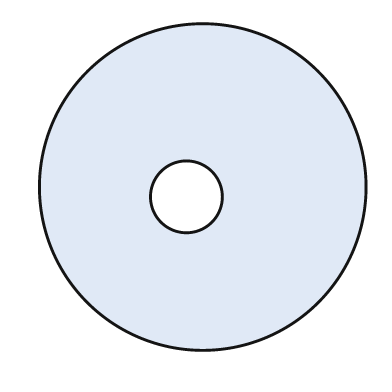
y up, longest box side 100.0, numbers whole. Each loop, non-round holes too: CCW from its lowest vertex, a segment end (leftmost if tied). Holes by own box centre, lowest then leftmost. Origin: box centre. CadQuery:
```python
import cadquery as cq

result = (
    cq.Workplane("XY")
    .moveTo(0.0, 0.0)
    .circle(50.0)
    .moveTo(-5.0, -3.0)
    .circle(11.0)
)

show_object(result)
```